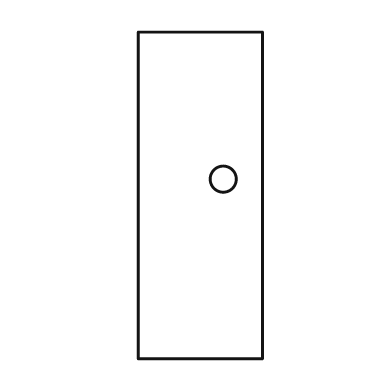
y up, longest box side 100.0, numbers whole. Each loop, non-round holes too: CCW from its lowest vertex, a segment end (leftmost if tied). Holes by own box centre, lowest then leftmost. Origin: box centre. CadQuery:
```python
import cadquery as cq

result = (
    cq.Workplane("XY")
    .moveTo(-19.0, -50.0)
    .lineTo(19.0, -50.0)
    .lineTo(19.0, 50.0)
    .lineTo(-19.0, 50.0)
    .close()
    .moveTo(7.0, 5.0)
    .circle(4.0)
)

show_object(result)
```